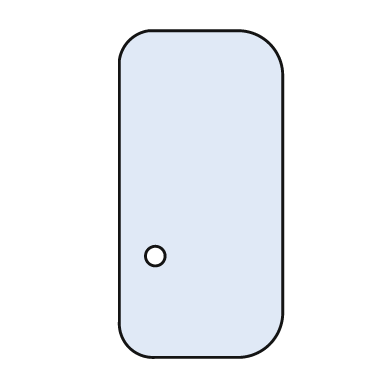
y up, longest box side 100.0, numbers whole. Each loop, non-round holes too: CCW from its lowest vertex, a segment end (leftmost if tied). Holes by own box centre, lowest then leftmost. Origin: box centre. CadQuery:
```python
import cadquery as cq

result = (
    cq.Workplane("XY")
    .moveTo(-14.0, -50.0)
    .lineTo(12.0, -50.0)
    .threePointArc((21.0, -46.0), (25.0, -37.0))
    .lineTo(25.0, 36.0)
    .threePointArc((21.0, 46.0), (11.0, 50.0))
    .lineTo(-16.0, 50.0)
    .threePointArc((-22.0, 47.0), (-25.0, 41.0))
    .lineTo(-25.0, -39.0)
    .threePointArc((-22.0, -47.0), (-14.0, -50.0))
    .close()
    .moveTo(-14.0, -19.0)
    .circle(3.0)
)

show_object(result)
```